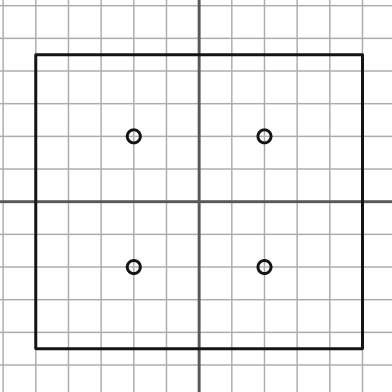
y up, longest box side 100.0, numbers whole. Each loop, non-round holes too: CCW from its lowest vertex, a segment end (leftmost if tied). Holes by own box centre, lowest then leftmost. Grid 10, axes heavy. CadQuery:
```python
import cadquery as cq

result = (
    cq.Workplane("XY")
    .moveTo(-50.0, -45.0)
    .lineTo(50.0, -45.0)
    .lineTo(50.0, 45.0)
    .lineTo(-50.0, 45.0)
    .close()
    .moveTo(-20.0, -20.0)
    .circle(2.0)
    .moveTo(20.0, -20.0)
    .circle(2.0)
    .moveTo(-20.0, 20.0)
    .circle(2.0)
    .moveTo(20.0, 20.0)
    .circle(2.0)
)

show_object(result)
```